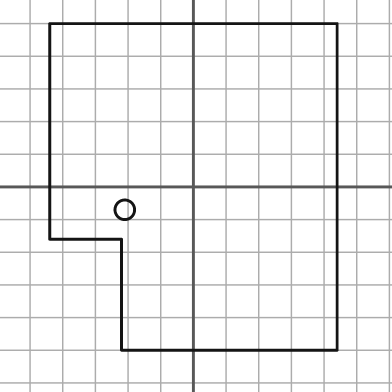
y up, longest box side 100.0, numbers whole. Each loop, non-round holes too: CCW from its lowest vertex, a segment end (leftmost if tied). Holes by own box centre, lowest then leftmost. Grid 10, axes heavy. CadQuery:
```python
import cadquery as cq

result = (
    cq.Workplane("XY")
    .moveTo(-22.0, -50.0)
    .lineTo(44.0, -50.0)
    .lineTo(44.0, 50.0)
    .lineTo(-44.0, 50.0)
    .lineTo(-44.0, -16.0)
    .lineTo(-22.0, -16.0)
    .close()
    .moveTo(-21.0, -7.0)
    .circle(3.0)
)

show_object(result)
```